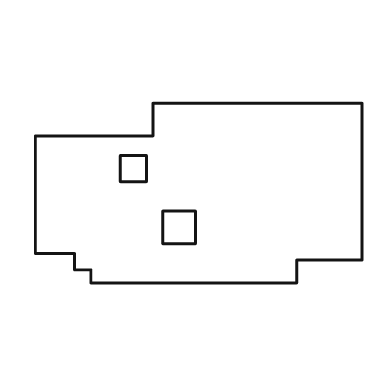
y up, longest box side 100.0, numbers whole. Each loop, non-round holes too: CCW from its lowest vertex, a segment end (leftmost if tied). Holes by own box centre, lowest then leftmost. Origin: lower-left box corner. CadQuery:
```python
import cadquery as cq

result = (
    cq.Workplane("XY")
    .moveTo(17.0, 0.0)
    .lineTo(80.0, 0.0)
    .lineTo(80.0, 7.0)
    .lineTo(100.0, 7.0)
    .lineTo(100.0, 55.0)
    .lineTo(36.0, 55.0)
    .lineTo(36.0, 45.0)
    .lineTo(0.0, 45.0)
    .lineTo(0.0, 9.0)
    .lineTo(12.0, 9.0)
    .lineTo(12.0, 4.0)
    .lineTo(17.0, 4.0)
    .close()
    .moveTo(39.0, 12.0)
    .lineTo(49.0, 12.0)
    .lineTo(49.0, 22.0)
    .lineTo(39.0, 22.0)
    .close()
    .moveTo(26.0, 31.0)
    .lineTo(34.0, 31.0)
    .lineTo(34.0, 39.0)
    .lineTo(26.0, 39.0)
    .close()
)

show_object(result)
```